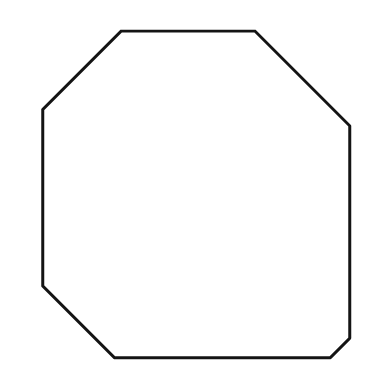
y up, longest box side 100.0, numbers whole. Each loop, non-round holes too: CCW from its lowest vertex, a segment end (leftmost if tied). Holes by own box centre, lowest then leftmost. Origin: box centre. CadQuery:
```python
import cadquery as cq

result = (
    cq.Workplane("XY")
    .moveTo(-25.0, -50.0)
    .lineTo(41.0, -50.0)
    .lineTo(47.0, -44.0)
    .lineTo(47.0, 21.0)
    .lineTo(18.0, 50.0)
    .lineTo(-23.0, 50.0)
    .lineTo(-47.0, 26.0)
    .lineTo(-47.0, -28.0)
    .close()
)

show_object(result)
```